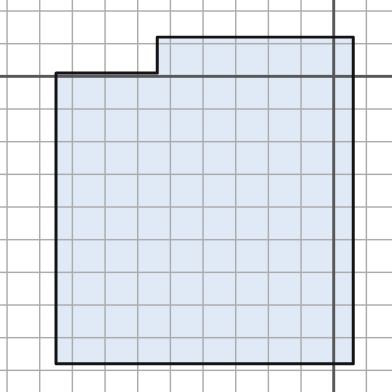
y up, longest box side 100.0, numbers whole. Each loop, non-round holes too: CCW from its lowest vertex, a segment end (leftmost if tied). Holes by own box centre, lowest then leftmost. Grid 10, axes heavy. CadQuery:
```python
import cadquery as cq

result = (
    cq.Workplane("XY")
    .moveTo(-85.0, -88.0)
    .lineTo(6.0, -88.0)
    .lineTo(6.0, 12.0)
    .lineTo(-54.0, 12.0)
    .lineTo(-54.0, 1.0)
    .lineTo(-85.0, 1.0)
    .close()
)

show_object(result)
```